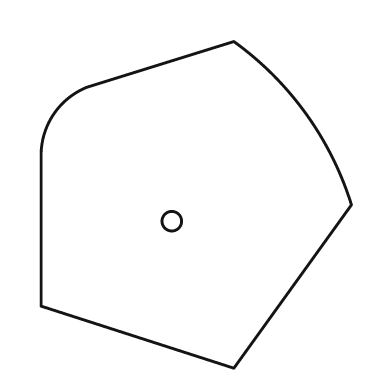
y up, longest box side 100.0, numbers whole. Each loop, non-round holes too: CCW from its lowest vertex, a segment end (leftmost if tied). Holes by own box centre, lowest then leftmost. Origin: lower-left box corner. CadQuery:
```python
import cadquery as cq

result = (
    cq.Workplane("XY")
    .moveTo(59.0, 0.0)
    .lineTo(95.0, 50.0)
    .threePointArc((81.0, 78.0), (59.0, 100.0))
    .lineTo(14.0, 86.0)
    .threePointArc((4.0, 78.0), (0.0, 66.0))
    .lineTo(0.0, 19.0)
    .close()
    .moveTo(40.0, 45.0)
    .circle(3.0)
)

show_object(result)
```